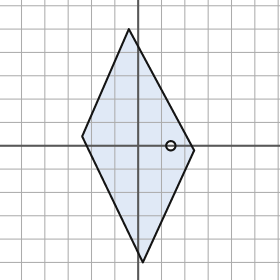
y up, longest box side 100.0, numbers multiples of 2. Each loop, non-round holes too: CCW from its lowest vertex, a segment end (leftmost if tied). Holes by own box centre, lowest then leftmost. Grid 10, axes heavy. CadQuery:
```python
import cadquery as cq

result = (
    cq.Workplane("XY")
    .moveTo(2.0, -50.0)
    .lineTo(24.0, -2.0)
    .lineTo(-4.0, 50.0)
    .lineTo(-24.0, 4.0)
    .close()
    .moveTo(14.0, 0.0)
    .circle(2.0)
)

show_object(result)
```